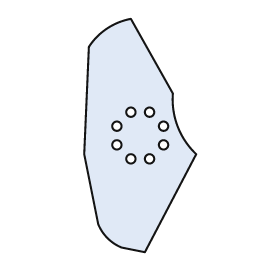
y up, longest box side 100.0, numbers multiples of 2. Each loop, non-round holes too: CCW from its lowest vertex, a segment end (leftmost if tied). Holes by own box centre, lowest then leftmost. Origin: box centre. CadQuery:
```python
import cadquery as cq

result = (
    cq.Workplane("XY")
    .moveTo(2.0, -50.0)
    .lineTo(24.0, -8.0)
    .threePointArc((16.0, 4.0), (14.0, 18.0))
    .lineTo(-4.0, 50.0)
    .threePointArc((-14.0, 46.0), (-22.0, 38.0))
    .lineTo(-24.0, -8.0)
    .lineTo(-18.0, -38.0)
    .threePointArc((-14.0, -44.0), (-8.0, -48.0))
    .close()
    .moveTo(-4.0, -10.0)
    .circle(2.0)
    .moveTo(4.0, -10.0)
    .circle(2.0)
    .moveTo(-10.0, -4.0)
    .circle(2.0)
    .moveTo(10.0, -4.0)
    .circle(2.0)
    .moveTo(-10.0, 4.0)
    .circle(2.0)
    .moveTo(10.0, 4.0)
    .circle(2.0)
    .moveTo(-4.0, 10.0)
    .circle(2.0)
    .moveTo(4.0, 10.0)
    .circle(2.0)
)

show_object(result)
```